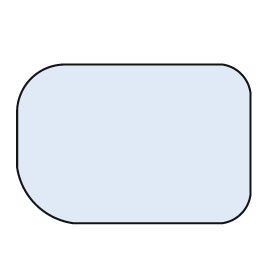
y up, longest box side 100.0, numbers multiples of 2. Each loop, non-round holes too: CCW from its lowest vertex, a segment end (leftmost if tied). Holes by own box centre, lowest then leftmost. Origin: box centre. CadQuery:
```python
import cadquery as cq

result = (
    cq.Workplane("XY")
    .moveTo(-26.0, -34.0)
    .lineTo(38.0, -34.0)
    .threePointArc((46.0, -30.0), (50.0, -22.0))
    .lineTo(50.0, 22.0)
    .threePointArc((46.0, 30.0), (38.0, 34.0))
    .lineTo(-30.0, 34.0)
    .threePointArc((-44.0, 28.0), (-50.0, 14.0))
    .lineTo(-50.0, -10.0)
    .threePointArc((-42.0, -26.0), (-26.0, -34.0))
    .close()
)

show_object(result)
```